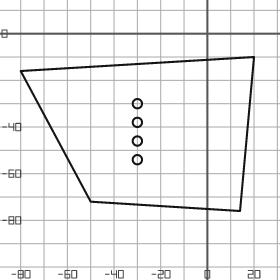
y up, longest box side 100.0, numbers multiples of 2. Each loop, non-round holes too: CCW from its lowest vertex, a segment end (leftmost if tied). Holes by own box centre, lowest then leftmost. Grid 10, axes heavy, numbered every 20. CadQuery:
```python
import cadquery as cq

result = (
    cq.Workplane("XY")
    .moveTo(14.0, -76.0)
    .lineTo(20.0, -10.0)
    .lineTo(-80.0, -16.0)
    .lineTo(-50.0, -72.0)
    .close()
    .moveTo(-30.0, -54.0)
    .circle(2.0)
    .moveTo(-30.0, -46.0)
    .circle(2.0)
    .moveTo(-30.0, -38.0)
    .circle(2.0)
    .moveTo(-30.0, -30.0)
    .circle(2.0)
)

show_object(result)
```